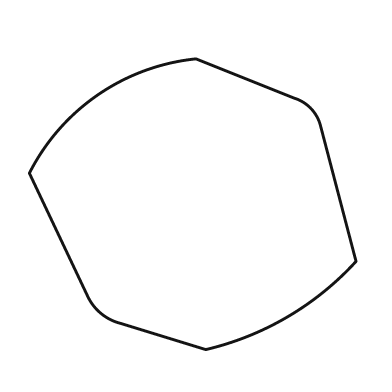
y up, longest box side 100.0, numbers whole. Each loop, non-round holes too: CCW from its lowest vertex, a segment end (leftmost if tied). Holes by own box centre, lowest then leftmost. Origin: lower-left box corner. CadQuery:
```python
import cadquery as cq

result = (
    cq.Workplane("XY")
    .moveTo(54.0, 0.0)
    .threePointArc((79.0, 10.0), (100.0, 27.0))
    .lineTo(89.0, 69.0)
    .threePointArc((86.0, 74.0), (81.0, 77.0))
    .lineTo(51.0, 89.0)
    .threePointArc((21.0, 78.0), (0.0, 54.0))
    .lineTo(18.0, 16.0)
    .threePointArc((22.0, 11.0), (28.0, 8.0))
    .close()
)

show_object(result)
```